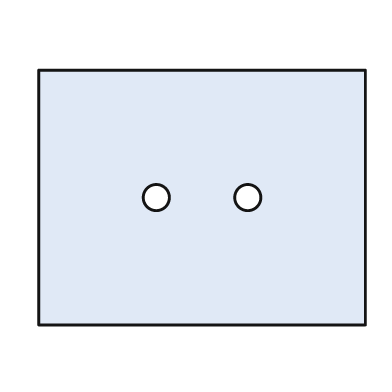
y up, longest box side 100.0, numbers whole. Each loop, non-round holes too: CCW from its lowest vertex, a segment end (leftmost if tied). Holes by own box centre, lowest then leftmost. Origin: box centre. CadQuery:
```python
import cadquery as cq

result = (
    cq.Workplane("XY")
    .moveTo(-50.0, -39.0)
    .lineTo(50.0, -39.0)
    .lineTo(50.0, 39.0)
    .lineTo(-50.0, 39.0)
    .close()
    .moveTo(-14.0, 0.0)
    .circle(4.0)
    .moveTo(14.0, 0.0)
    .circle(4.0)
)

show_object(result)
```